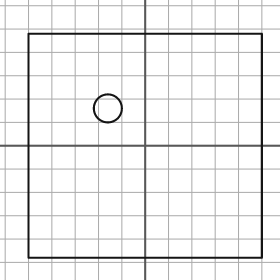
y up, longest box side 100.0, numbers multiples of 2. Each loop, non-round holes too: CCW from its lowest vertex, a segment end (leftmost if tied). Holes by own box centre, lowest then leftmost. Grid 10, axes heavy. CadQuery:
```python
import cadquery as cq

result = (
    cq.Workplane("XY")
    .moveTo(-50.0, -48.0)
    .lineTo(50.0, -48.0)
    .lineTo(50.0, 48.0)
    .lineTo(-50.0, 48.0)
    .close()
    .moveTo(-16.0, 16.0)
    .circle(6.0)
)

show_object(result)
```